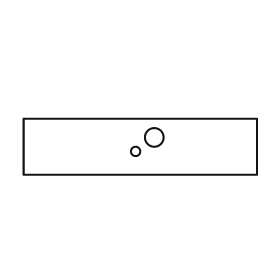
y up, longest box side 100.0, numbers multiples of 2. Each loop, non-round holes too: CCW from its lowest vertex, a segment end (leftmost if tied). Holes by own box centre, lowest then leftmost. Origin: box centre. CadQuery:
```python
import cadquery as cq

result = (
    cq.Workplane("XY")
    .moveTo(-50.0, -12.0)
    .lineTo(50.0, -12.0)
    .lineTo(50.0, 12.0)
    .lineTo(-50.0, 12.0)
    .close()
    .moveTo(-2.0, -2.0)
    .circle(2.0)
    .moveTo(6.0, 4.0)
    .circle(4.0)
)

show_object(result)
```